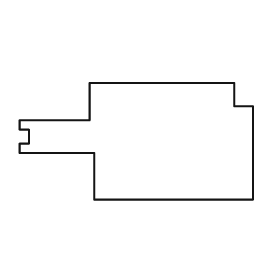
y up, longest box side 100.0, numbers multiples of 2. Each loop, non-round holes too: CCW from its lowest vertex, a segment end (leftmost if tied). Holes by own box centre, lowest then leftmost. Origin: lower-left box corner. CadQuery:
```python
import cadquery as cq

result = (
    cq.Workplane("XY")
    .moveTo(32.0, 0.0)
    .lineTo(100.0, 0.0)
    .lineTo(100.0, 40.0)
    .lineTo(92.0, 40.0)
    .lineTo(92.0, 50.0)
    .lineTo(30.0, 50.0)
    .lineTo(30.0, 34.0)
    .lineTo(0.0, 34.0)
    .lineTo(0.0, 30.0)
    .lineTo(4.0, 30.0)
    .lineTo(4.0, 24.0)
    .lineTo(0.0, 24.0)
    .lineTo(0.0, 20.0)
    .lineTo(32.0, 20.0)
    .close()
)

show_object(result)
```